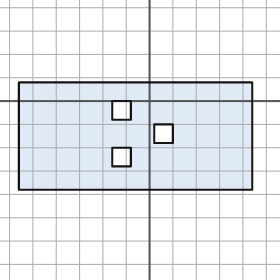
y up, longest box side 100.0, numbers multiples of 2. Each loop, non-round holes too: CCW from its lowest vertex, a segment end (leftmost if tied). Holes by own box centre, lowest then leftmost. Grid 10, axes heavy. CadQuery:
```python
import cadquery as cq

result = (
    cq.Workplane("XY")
    .moveTo(-56.0, -38.0)
    .lineTo(44.0, -38.0)
    .lineTo(44.0, 8.0)
    .lineTo(-56.0, 8.0)
    .close()
    .moveTo(-16.0, -28.0)
    .lineTo(-8.0, -28.0)
    .lineTo(-8.0, -20.0)
    .lineTo(-16.0, -20.0)
    .close()
    .moveTo(2.0, -18.0)
    .lineTo(10.0, -18.0)
    .lineTo(10.0, -10.0)
    .lineTo(2.0, -10.0)
    .close()
    .moveTo(-16.0, -8.0)
    .lineTo(-8.0, -8.0)
    .lineTo(-8.0, 0.0)
    .lineTo(-16.0, 0.0)
    .close()
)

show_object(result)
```